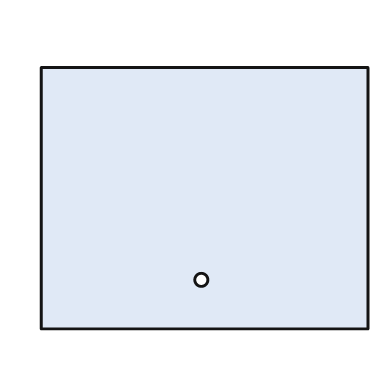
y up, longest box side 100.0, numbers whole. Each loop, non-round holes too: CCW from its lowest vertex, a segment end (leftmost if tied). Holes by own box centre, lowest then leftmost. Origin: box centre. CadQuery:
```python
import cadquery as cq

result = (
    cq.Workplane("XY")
    .moveTo(-50.0, -40.0)
    .lineTo(50.0, -40.0)
    .lineTo(50.0, 40.0)
    .lineTo(-50.0, 40.0)
    .close()
    .moveTo(-1.0, -25.0)
    .circle(2.0)
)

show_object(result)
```